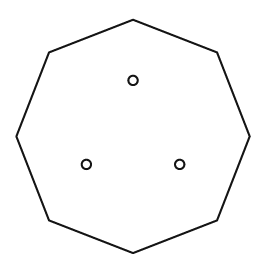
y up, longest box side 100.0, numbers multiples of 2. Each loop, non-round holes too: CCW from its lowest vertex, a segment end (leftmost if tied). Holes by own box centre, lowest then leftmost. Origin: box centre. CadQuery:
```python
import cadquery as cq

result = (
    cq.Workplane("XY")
    .moveTo(0.0, -50.0)
    .lineTo(36.0, -36.0)
    .lineTo(50.0, 0.0)
    .lineTo(36.0, 36.0)
    .lineTo(0.0, 50.0)
    .lineTo(-36.0, 36.0)
    .lineTo(-50.0, 0.0)
    .lineTo(-36.0, -36.0)
    .close()
    .moveTo(-20.0, -12.0)
    .circle(2.0)
    .moveTo(20.0, -12.0)
    .circle(2.0)
    .moveTo(0.0, 24.0)
    .circle(2.0)
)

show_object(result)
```